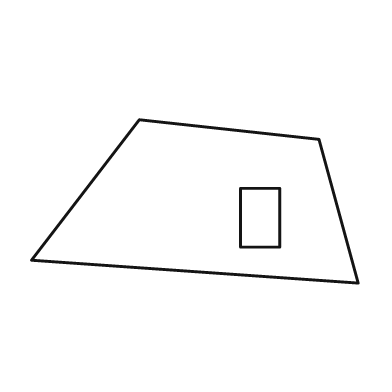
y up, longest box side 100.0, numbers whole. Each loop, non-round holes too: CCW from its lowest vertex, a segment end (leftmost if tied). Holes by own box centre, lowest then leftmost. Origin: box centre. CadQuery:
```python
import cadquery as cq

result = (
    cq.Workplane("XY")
    .moveTo(50.0, -25.0)
    .lineTo(38.0, 19.0)
    .lineTo(-17.0, 25.0)
    .lineTo(-50.0, -18.0)
    .close()
    .moveTo(14.0, -14.0)
    .lineTo(26.0, -14.0)
    .lineTo(26.0, 4.0)
    .lineTo(14.0, 4.0)
    .close()
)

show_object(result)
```